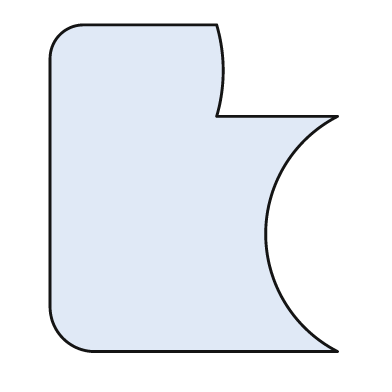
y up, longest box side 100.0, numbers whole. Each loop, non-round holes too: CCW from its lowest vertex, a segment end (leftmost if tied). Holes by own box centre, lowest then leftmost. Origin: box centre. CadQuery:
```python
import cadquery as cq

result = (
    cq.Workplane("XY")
    .moveTo(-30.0, -50.0)
    .lineTo(44.0, -50.0)
    .threePointArc((22.0, -14.0), (44.0, 22.0))
    .lineTo(7.0, 22.0)
    .threePointArc((9.0, 36.0), (7.0, 50.0))
    .lineTo(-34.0, 50.0)
    .threePointArc((-41.0, 47.0), (-44.0, 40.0))
    .lineTo(-44.0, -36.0)
    .threePointArc((-40.0, -46.0), (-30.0, -50.0))
    .close()
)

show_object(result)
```